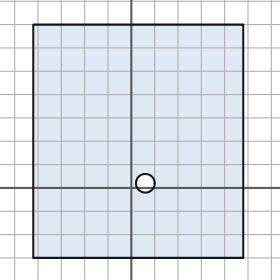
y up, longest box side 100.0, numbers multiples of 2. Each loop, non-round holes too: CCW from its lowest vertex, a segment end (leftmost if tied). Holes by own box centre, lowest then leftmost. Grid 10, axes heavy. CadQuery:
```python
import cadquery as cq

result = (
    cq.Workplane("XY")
    .moveTo(-42.0, -30.0)
    .lineTo(48.0, -30.0)
    .lineTo(48.0, 70.0)
    .lineTo(-42.0, 70.0)
    .close()
    .moveTo(6.0, 2.0)
    .circle(4.0)
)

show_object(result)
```